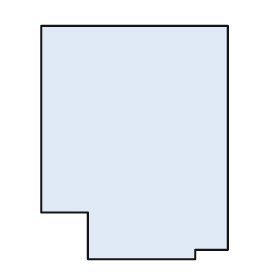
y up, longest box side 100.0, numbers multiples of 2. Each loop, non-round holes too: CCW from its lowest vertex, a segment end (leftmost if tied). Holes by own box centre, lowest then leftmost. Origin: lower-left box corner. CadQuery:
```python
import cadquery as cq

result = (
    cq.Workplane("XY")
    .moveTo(20.0, 0.0)
    .lineTo(66.0, 0.0)
    .lineTo(66.0, 4.0)
    .lineTo(80.0, 4.0)
    .lineTo(80.0, 100.0)
    .lineTo(0.0, 100.0)
    .lineTo(0.0, 20.0)
    .lineTo(20.0, 20.0)
    .close()
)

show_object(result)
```